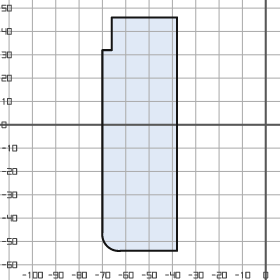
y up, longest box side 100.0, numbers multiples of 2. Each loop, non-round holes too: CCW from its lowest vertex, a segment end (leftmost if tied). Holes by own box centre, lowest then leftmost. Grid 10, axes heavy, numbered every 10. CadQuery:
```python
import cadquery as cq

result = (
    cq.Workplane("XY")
    .moveTo(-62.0, -54.0)
    .lineTo(-38.0, -54.0)
    .lineTo(-38.0, 46.0)
    .lineTo(-66.0, 46.0)
    .lineTo(-66.0, 32.0)
    .lineTo(-70.0, 32.0)
    .lineTo(-70.0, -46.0)
    .threePointArc((-68.0, -52.0), (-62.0, -54.0))
    .close()
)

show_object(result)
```